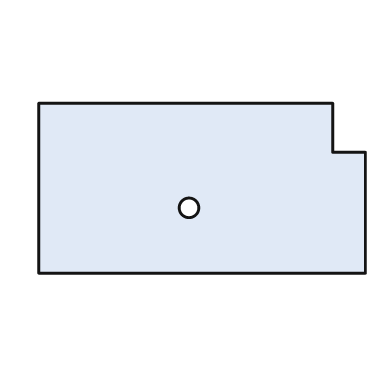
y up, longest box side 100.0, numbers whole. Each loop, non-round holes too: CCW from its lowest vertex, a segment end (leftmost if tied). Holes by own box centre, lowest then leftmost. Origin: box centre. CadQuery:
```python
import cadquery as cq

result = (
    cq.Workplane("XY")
    .moveTo(-50.0, -26.0)
    .lineTo(50.0, -26.0)
    .lineTo(50.0, 11.0)
    .lineTo(40.0, 11.0)
    .lineTo(40.0, 26.0)
    .lineTo(-50.0, 26.0)
    .close()
    .moveTo(-4.0, -6.0)
    .circle(3.0)
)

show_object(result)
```